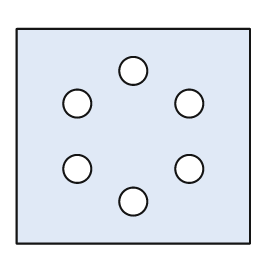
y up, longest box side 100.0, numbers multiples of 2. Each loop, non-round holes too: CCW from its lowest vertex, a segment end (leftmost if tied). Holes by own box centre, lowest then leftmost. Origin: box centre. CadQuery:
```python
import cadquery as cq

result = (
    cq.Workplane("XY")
    .moveTo(-50.0, -46.0)
    .lineTo(50.0, -46.0)
    .lineTo(50.0, 46.0)
    .lineTo(-50.0, 46.0)
    .close()
    .moveTo(0.0, -28.0)
    .circle(6.0)
    .moveTo(-24.0, -14.0)
    .circle(6.0)
    .moveTo(24.0, -14.0)
    .circle(6.0)
    .moveTo(-24.0, 14.0)
    .circle(6.0)
    .moveTo(24.0, 14.0)
    .circle(6.0)
    .moveTo(0.0, 28.0)
    .circle(6.0)
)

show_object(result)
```